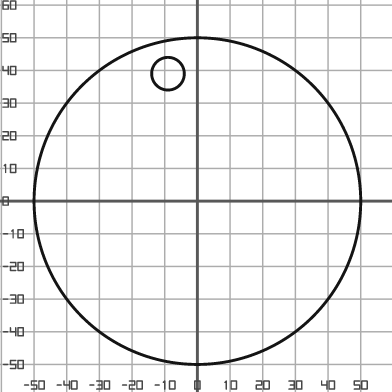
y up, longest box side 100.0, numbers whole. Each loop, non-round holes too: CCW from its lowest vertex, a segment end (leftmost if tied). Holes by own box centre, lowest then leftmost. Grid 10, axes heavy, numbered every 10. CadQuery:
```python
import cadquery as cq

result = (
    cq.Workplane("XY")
    .moveTo(0.0, 0.0)
    .circle(50.0)
    .moveTo(-9.0, 39.0)
    .circle(5.0)
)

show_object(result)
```